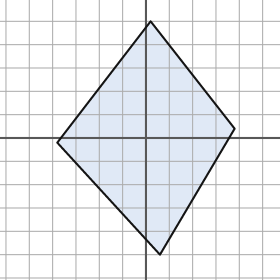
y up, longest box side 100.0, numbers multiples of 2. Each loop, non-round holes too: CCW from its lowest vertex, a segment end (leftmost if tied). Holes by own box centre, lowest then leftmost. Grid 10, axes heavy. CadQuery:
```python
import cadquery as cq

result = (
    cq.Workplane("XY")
    .moveTo(6.0, -50.0)
    .lineTo(38.0, 4.0)
    .lineTo(2.0, 50.0)
    .lineTo(-38.0, -2.0)
    .close()
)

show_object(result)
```